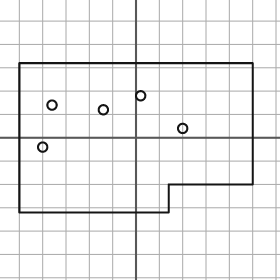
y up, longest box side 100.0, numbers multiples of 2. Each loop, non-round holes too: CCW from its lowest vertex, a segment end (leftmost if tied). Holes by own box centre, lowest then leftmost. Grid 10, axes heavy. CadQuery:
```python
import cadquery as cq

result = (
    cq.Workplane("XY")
    .moveTo(-50.0, -32.0)
    .lineTo(14.0, -32.0)
    .lineTo(14.0, -20.0)
    .lineTo(50.0, -20.0)
    .lineTo(50.0, 32.0)
    .lineTo(-50.0, 32.0)
    .close()
    .moveTo(-40.0, -4.0)
    .circle(2.0)
    .moveTo(20.0, 4.0)
    .circle(2.0)
    .moveTo(-14.0, 12.0)
    .circle(2.0)
    .moveTo(-36.0, 14.0)
    .circle(2.0)
    .moveTo(2.0, 18.0)
    .circle(2.0)
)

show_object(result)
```